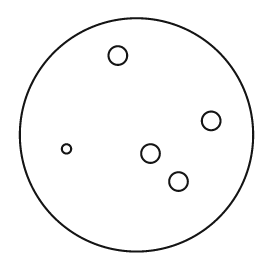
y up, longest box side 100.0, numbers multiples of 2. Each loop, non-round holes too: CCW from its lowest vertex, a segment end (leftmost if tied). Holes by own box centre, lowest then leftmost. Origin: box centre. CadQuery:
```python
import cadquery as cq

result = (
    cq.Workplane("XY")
    .moveTo(0.0, 0.0)
    .circle(50.0)
    .moveTo(18.0, -20.0)
    .circle(4.0)
    .moveTo(6.0, -8.0)
    .circle(4.0)
    .moveTo(-30.0, -6.0)
    .circle(2.0)
    .moveTo(32.0, 6.0)
    .circle(4.0)
    .moveTo(-8.0, 34.0)
    .circle(4.0)
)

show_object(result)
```